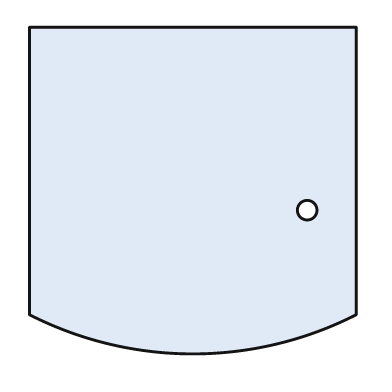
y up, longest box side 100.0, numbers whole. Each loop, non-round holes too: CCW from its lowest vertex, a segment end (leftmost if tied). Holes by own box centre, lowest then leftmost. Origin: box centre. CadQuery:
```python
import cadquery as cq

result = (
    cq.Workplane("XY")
    .moveTo(-50.0, -38.0)
    .threePointArc((0.0, -50.0), (50.0, -38.0))
    .lineTo(50.0, 50.0)
    .lineTo(-50.0, 50.0)
    .close()
    .moveTo(35.0, -6.0)
    .circle(3.0)
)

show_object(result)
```